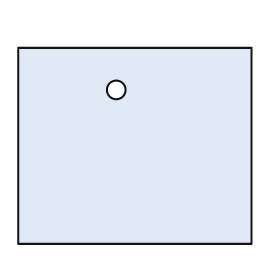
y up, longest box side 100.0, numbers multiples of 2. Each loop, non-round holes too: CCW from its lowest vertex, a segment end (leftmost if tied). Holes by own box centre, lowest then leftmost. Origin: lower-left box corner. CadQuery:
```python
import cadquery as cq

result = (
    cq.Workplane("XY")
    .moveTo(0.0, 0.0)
    .lineTo(100.0, 0.0)
    .lineTo(100.0, 84.0)
    .lineTo(0.0, 84.0)
    .close()
    .moveTo(42.0, 66.0)
    .circle(4.0)
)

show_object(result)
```